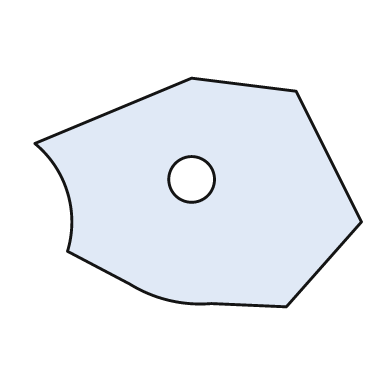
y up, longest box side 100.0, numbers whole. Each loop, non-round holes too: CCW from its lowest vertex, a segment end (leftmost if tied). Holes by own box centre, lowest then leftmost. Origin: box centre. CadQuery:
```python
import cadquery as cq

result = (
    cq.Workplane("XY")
    .moveTo(27.0, -35.0)
    .lineTo(50.0, -9.0)
    .lineTo(30.0, 31.0)
    .lineTo(-2.0, 35.0)
    .lineTo(-50.0, 15.0)
    .threePointArc((-40.0, 0.0), (-40.0, -18.0))
    .lineTo(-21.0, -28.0)
    .threePointArc((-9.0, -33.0), (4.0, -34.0))
    .close()
    .moveTo(-2.0, 4.0)
    .circle(7.0)
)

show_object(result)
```